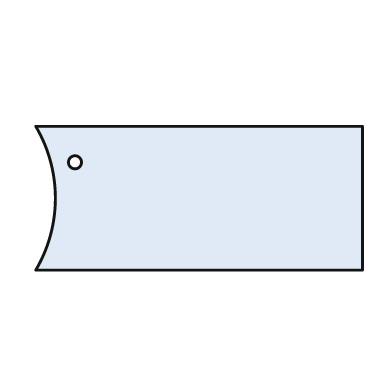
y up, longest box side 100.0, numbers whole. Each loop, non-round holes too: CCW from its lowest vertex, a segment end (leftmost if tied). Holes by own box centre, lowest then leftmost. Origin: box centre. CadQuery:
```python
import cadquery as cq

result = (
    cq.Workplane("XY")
    .moveTo(-50.0, -22.0)
    .lineTo(50.0, -22.0)
    .lineTo(50.0, 22.0)
    .lineTo(-50.0, 22.0)
    .threePointArc((-44.0, 0.0), (-50.0, -22.0))
    .close()
    .moveTo(-38.0, 11.0)
    .circle(2.0)
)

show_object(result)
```